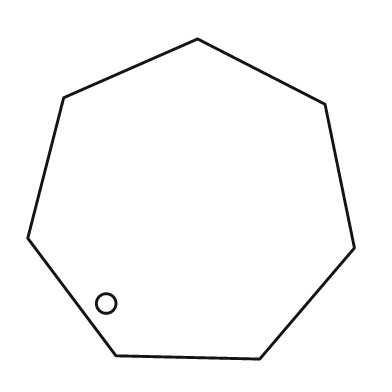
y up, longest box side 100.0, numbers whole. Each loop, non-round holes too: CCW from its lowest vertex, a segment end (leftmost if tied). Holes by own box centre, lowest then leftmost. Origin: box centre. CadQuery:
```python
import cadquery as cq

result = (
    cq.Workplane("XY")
    .moveTo(21.0, -49.0)
    .lineTo(50.0, -15.0)
    .lineTo(41.0, 29.0)
    .lineTo(2.0, 49.0)
    .lineTo(-39.0, 31.0)
    .lineTo(-50.0, -12.0)
    .lineTo(-23.0, -48.0)
    .close()
    .moveTo(-26.0, -32.0)
    .circle(3.0)
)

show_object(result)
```